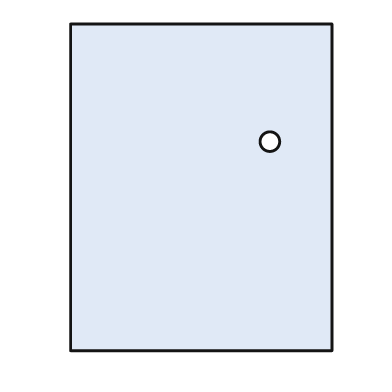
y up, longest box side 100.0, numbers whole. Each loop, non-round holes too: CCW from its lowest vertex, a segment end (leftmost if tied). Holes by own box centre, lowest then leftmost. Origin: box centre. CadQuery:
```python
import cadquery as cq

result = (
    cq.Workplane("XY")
    .moveTo(-40.0, -50.0)
    .lineTo(40.0, -50.0)
    .lineTo(40.0, 50.0)
    .lineTo(-40.0, 50.0)
    .close()
    .moveTo(21.0, 14.0)
    .circle(3.0)
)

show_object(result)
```